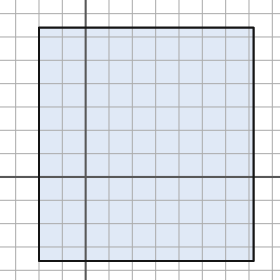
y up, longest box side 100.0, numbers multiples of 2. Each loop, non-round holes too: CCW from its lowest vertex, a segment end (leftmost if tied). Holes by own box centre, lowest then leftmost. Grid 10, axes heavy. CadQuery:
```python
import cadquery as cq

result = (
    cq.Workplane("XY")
    .moveTo(-20.0, -36.0)
    .lineTo(72.0, -36.0)
    .lineTo(72.0, 64.0)
    .lineTo(-20.0, 64.0)
    .close()
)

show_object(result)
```